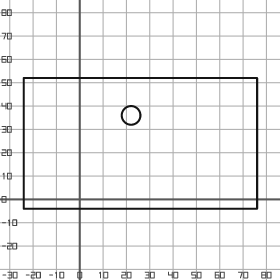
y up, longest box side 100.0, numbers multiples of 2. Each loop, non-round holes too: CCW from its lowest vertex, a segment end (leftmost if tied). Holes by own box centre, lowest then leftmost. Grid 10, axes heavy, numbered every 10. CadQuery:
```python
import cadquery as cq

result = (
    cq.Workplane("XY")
    .moveTo(-24.0, -4.0)
    .lineTo(76.0, -4.0)
    .lineTo(76.0, 52.0)
    .lineTo(-24.0, 52.0)
    .close()
    .moveTo(22.0, 36.0)
    .circle(4.0)
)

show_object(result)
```